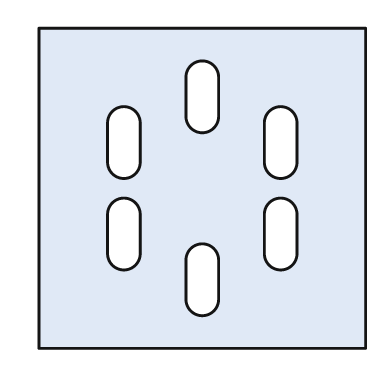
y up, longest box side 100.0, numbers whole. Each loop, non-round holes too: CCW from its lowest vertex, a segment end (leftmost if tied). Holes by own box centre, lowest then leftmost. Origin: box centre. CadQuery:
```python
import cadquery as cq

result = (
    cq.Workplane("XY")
    .moveTo(-50.0, -49.0)
    .lineTo(50.0, -49.0)
    .lineTo(50.0, 49.0)
    .lineTo(-50.0, 49.0)
    .close()
    .moveTo(-5.0, -34.0)
    .threePointArc((0.0, -39.0), (5.0, -34.0))
    .lineTo(5.0, -22.0)
    .threePointArc((0.0, -17.0), (-5.0, -22.0))
    .close()
    .moveTo(-29.0, -20.0)
    .threePointArc((-24.0, -25.0), (-19.0, -20.0))
    .lineTo(-19.0, -8.0)
    .threePointArc((-24.0, -3.0), (-29.0, -8.0))
    .close()
    .moveTo(19.0, -20.0)
    .threePointArc((24.0, -25.0), (29.0, -20.0))
    .lineTo(29.0, -8.0)
    .threePointArc((24.0, -3.0), (19.0, -8.0))
    .close()
    .moveTo(-29.0, 8.0)
    .threePointArc((-24.0, 3.0), (-19.0, 8.0))
    .lineTo(-19.0, 20.0)
    .threePointArc((-24.0, 25.0), (-29.0, 20.0))
    .close()
    .moveTo(19.0, 8.0)
    .threePointArc((24.0, 3.0), (29.0, 8.0))
    .lineTo(29.0, 20.0)
    .threePointArc((24.0, 25.0), (19.0, 20.0))
    .close()
    .moveTo(-5.0, 22.0)
    .threePointArc((0.0, 17.0), (5.0, 22.0))
    .lineTo(5.0, 34.0)
    .threePointArc((0.0, 39.0), (-5.0, 34.0))
    .close()
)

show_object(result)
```